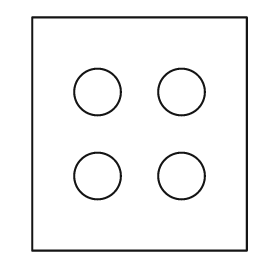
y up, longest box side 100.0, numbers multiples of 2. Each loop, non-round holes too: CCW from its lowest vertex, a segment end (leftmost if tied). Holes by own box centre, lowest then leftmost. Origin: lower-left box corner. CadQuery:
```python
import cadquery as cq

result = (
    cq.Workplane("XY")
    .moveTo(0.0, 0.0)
    .lineTo(92.0, 0.0)
    .lineTo(92.0, 100.0)
    .lineTo(0.0, 100.0)
    .close()
    .moveTo(28.0, 32.0)
    .circle(10.0)
    .moveTo(64.0, 32.0)
    .circle(10.0)
    .moveTo(28.0, 68.0)
    .circle(10.0)
    .moveTo(64.0, 68.0)
    .circle(10.0)
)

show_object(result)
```